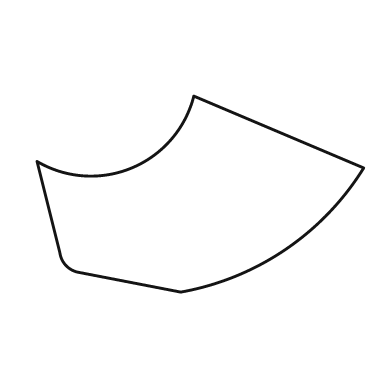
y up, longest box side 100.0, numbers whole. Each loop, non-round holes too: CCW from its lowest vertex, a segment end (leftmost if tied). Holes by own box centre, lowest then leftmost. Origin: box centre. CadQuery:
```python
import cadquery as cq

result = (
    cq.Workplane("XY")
    .moveTo(-6.0, -30.0)
    .threePointArc((26.0, -17.0), (50.0, 8.0))
    .lineTo(-2.0, 30.0)
    .threePointArc((-21.0, 8.0), (-50.0, 10.0))
    .lineTo(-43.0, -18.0)
    .threePointArc((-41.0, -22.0), (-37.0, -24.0))
    .close()
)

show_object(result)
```